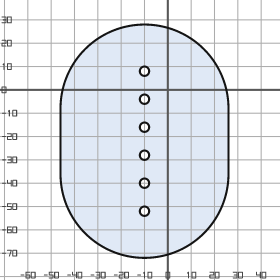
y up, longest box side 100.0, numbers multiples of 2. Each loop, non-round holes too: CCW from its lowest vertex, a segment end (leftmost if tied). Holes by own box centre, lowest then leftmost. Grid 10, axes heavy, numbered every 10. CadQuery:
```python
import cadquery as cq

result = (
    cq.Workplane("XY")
    .moveTo(-46.0, -36.0)
    .threePointArc((-10.0, -72.0), (26.0, -36.0))
    .lineTo(26.0, -8.0)
    .threePointArc((-10.0, 28.0), (-46.0, -8.0))
    .close()
    .moveTo(-10.0, -52.0)
    .circle(2.0)
    .moveTo(-10.0, -40.0)
    .circle(2.0)
    .moveTo(-10.0, -28.0)
    .circle(2.0)
    .moveTo(-10.0, -16.0)
    .circle(2.0)
    .moveTo(-10.0, -4.0)
    .circle(2.0)
    .moveTo(-10.0, 8.0)
    .circle(2.0)
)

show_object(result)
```